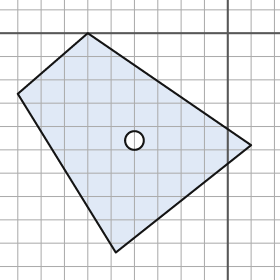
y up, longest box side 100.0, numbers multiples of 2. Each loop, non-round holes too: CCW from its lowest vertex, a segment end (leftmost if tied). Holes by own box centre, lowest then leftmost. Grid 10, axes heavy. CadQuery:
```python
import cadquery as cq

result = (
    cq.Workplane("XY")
    .moveTo(-48.0, -94.0)
    .lineTo(10.0, -48.0)
    .lineTo(-60.0, 0.0)
    .lineTo(-90.0, -26.0)
    .close()
    .moveTo(-40.0, -46.0)
    .circle(4.0)
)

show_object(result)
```